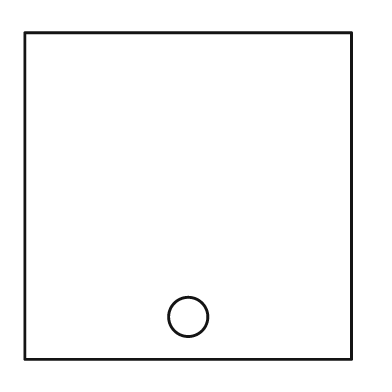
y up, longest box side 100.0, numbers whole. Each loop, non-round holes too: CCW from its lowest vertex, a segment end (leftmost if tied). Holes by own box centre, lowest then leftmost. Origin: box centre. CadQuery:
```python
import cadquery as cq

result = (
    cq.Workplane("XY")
    .moveTo(-50.0, -50.0)
    .lineTo(50.0, -50.0)
    .lineTo(50.0, 50.0)
    .lineTo(-50.0, 50.0)
    .close()
    .moveTo(0.0, -37.0)
    .circle(6.0)
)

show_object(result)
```